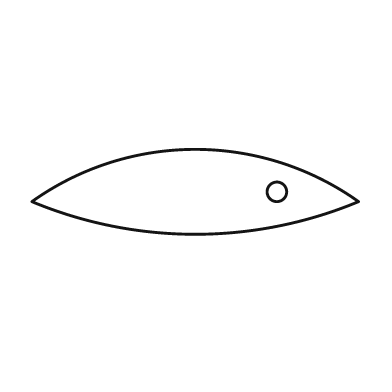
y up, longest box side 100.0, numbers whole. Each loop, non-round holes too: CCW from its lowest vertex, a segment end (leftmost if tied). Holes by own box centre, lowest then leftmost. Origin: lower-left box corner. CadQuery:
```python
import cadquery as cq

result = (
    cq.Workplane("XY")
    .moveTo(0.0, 10.0)
    .threePointArc((50.0, 0.0), (100.0, 10.0))
    .threePointArc((50.0, 26.0), (0.0, 10.0))
    .close()
    .moveTo(75.0, 13.0)
    .circle(3.0)
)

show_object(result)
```